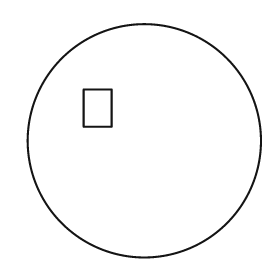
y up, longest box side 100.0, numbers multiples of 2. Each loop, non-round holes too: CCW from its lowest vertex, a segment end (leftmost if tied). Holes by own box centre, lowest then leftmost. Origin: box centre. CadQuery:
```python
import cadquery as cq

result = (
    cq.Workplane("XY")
    .moveTo(0.0, 0.0)
    .circle(50.0)
    .moveTo(-26.0, 6.0)
    .lineTo(-14.0, 6.0)
    .lineTo(-14.0, 22.0)
    .lineTo(-26.0, 22.0)
    .close()
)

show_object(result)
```